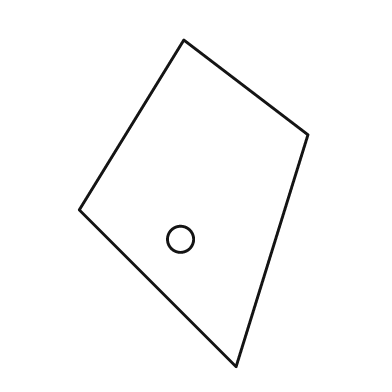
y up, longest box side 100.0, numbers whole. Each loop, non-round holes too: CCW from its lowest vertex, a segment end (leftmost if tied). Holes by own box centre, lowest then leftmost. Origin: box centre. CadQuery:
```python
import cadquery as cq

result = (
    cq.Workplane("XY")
    .moveTo(13.0, -50.0)
    .lineTo(35.0, 21.0)
    .lineTo(-3.0, 50.0)
    .lineTo(-35.0, -2.0)
    .close()
    .moveTo(-4.0, -11.0)
    .circle(4.0)
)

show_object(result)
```